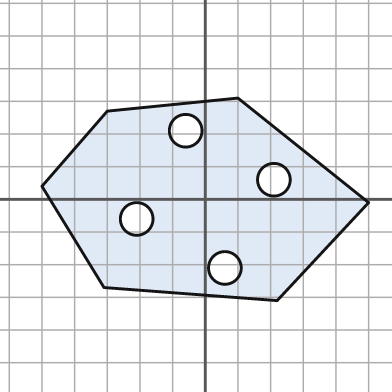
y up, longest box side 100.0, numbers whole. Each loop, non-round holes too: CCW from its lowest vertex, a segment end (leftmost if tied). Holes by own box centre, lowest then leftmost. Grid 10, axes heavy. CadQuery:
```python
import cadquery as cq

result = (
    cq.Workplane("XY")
    .moveTo(22.0, -31.0)
    .lineTo(50.0, -1.0)
    .lineTo(10.0, 31.0)
    .lineTo(-30.0, 27.0)
    .lineTo(-50.0, 4.0)
    .lineTo(-31.0, -27.0)
    .close()
    .moveTo(6.0, -21.0)
    .circle(5.0)
    .moveTo(-21.0, -6.0)
    .circle(5.0)
    .moveTo(21.0, 6.0)
    .circle(5.0)
    .moveTo(-6.0, 21.0)
    .circle(5.0)
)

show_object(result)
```